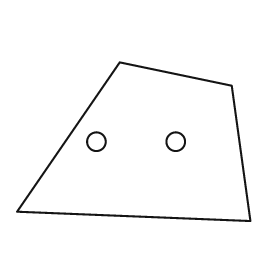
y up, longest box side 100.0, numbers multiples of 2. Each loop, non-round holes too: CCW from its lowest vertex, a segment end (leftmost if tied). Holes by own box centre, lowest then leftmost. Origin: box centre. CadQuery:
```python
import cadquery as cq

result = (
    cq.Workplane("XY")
    .moveTo(50.0, -34.0)
    .lineTo(42.0, 24.0)
    .lineTo(-6.0, 34.0)
    .lineTo(-50.0, -30.0)
    .close()
    .moveTo(-16.0, 0.0)
    .circle(4.0)
    .moveTo(18.0, 0.0)
    .circle(4.0)
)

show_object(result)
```